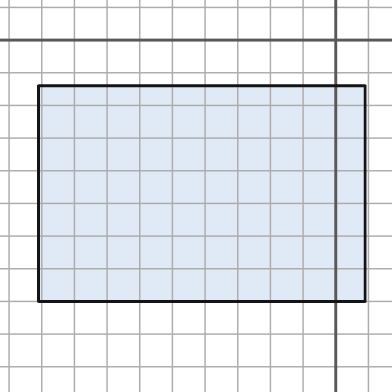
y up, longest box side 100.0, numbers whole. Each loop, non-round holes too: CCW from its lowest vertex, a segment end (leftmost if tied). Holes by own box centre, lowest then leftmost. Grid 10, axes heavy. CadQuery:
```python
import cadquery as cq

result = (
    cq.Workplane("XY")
    .moveTo(-91.0, -80.0)
    .lineTo(9.0, -80.0)
    .lineTo(9.0, -14.0)
    .lineTo(-91.0, -14.0)
    .close()
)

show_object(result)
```